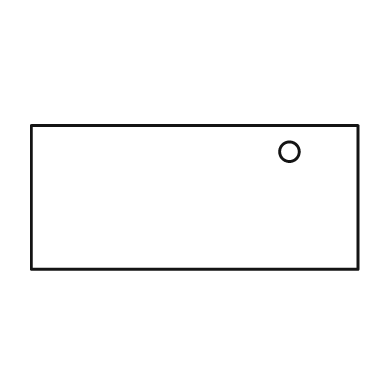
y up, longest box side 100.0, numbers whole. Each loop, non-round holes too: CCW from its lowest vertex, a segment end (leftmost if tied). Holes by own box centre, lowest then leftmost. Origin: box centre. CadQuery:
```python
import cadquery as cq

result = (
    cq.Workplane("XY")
    .moveTo(-50.0, -22.0)
    .lineTo(50.0, -22.0)
    .lineTo(50.0, 22.0)
    .lineTo(-50.0, 22.0)
    .close()
    .moveTo(29.0, 14.0)
    .circle(3.0)
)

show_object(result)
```